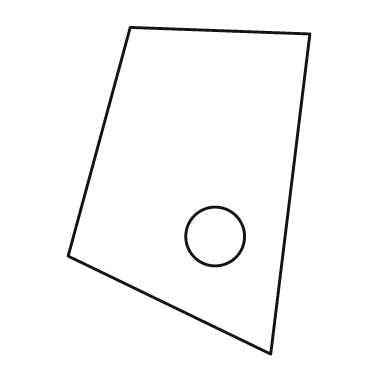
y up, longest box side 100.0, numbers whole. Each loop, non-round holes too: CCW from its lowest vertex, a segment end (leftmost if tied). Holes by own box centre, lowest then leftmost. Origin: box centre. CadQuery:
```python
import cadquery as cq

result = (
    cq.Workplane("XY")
    .moveTo(25.0, -50.0)
    .lineTo(37.0, 48.0)
    .lineTo(-18.0, 50.0)
    .lineTo(-37.0, -20.0)
    .close()
    .moveTo(8.0, -14.0)
    .circle(9.0)
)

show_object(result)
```